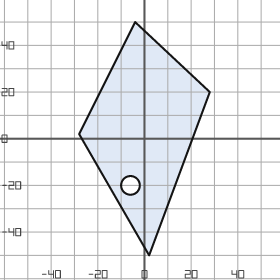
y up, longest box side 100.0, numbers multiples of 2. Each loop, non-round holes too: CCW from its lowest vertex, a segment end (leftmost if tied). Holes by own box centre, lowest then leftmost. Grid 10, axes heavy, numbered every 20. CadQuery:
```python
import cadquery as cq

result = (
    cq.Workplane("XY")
    .moveTo(2.0, -50.0)
    .lineTo(28.0, 20.0)
    .lineTo(-4.0, 50.0)
    .lineTo(-28.0, 2.0)
    .close()
    .moveTo(-6.0, -20.0)
    .circle(4.0)
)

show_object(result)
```